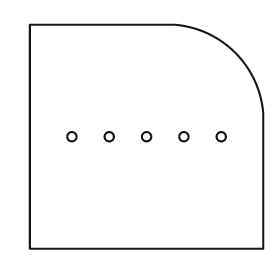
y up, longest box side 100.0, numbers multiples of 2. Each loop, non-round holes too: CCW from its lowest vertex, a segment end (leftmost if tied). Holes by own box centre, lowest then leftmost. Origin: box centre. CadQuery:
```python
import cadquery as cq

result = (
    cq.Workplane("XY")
    .moveTo(-50.0, -48.0)
    .lineTo(50.0, -48.0)
    .lineTo(50.0, 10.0)
    .threePointArc((38.0, 36.0), (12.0, 48.0))
    .lineTo(-50.0, 48.0)
    .close()
    .moveTo(-32.0, 0.0)
    .circle(2.0)
    .moveTo(-16.0, 0.0)
    .circle(2.0)
    .moveTo(0.0, 0.0)
    .circle(2.0)
    .moveTo(16.0, 0.0)
    .circle(2.0)
    .moveTo(32.0, 0.0)
    .circle(2.0)
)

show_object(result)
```